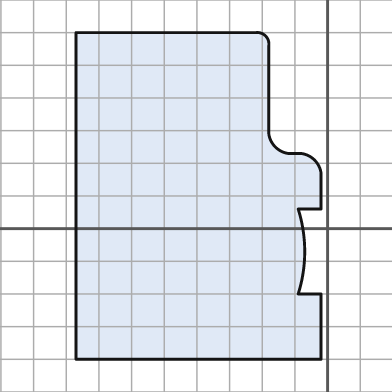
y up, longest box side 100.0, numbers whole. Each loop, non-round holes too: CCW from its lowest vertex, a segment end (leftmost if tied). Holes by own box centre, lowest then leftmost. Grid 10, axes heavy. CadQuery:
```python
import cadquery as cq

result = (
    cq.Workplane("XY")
    .moveTo(-77.0, -40.0)
    .lineTo(-2.0, -40.0)
    .lineTo(-2.0, -20.0)
    .lineTo(-9.0, -20.0)
    .threePointArc((-7.0, -7.0), (-9.0, 6.0))
    .lineTo(-2.0, 6.0)
    .lineTo(-2.0, 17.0)
    .threePointArc((-4.0, 21.0), (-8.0, 23.0))
    .lineTo(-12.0, 23.0)
    .threePointArc((-16.0, 25.0), (-18.0, 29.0))
    .lineTo(-18.0, 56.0)
    .threePointArc((-19.0, 59.0), (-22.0, 60.0))
    .lineTo(-77.0, 60.0)
    .close()
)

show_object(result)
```